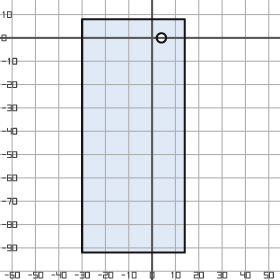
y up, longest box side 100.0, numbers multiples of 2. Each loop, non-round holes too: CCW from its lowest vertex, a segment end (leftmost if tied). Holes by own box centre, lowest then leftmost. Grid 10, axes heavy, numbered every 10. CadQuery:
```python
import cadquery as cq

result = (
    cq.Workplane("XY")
    .moveTo(-30.0, -92.0)
    .lineTo(14.0, -92.0)
    .lineTo(14.0, 8.0)
    .lineTo(-30.0, 8.0)
    .close()
    .moveTo(4.0, 0.0)
    .circle(2.0)
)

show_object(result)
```